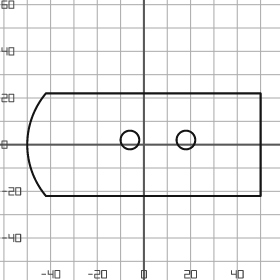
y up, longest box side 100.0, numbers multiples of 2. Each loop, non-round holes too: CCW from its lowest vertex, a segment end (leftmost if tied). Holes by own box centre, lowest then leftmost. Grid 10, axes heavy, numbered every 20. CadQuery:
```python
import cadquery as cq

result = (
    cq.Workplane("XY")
    .moveTo(-42.0, -22.0)
    .lineTo(50.0, -22.0)
    .lineTo(50.0, 22.0)
    .lineTo(-42.0, 22.0)
    .threePointArc((-50.0, 0.0), (-42.0, -22.0))
    .close()
    .moveTo(-6.0, 2.0)
    .circle(4.0)
    .moveTo(18.0, 2.0)
    .circle(4.0)
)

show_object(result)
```